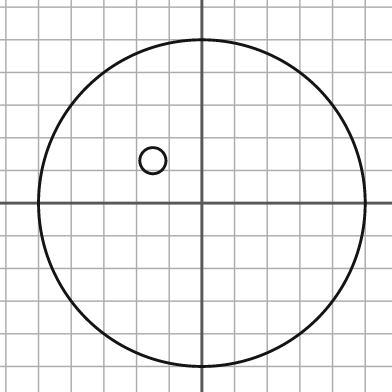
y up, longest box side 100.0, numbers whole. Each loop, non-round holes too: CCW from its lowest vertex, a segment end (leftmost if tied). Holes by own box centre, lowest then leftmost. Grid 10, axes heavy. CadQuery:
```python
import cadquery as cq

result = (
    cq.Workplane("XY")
    .moveTo(0.0, 0.0)
    .circle(50.0)
    .moveTo(-15.0, 13.0)
    .circle(4.0)
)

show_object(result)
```